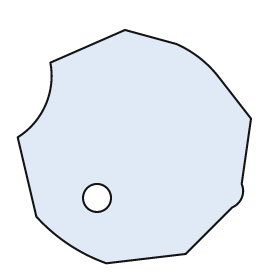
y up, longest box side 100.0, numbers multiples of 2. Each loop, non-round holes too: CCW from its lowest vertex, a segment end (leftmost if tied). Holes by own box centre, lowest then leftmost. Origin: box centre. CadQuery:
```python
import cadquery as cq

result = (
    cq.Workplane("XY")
    .moveTo(-12.0, -50.0)
    .lineTo(22.0, -46.0)
    .lineTo(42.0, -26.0)
    .threePointArc((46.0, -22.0), (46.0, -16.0))
    .lineTo(50.0, 12.0)
    .lineTo(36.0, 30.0)
    .threePointArc((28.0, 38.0), (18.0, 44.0))
    .lineTo(-4.0, 50.0)
    .lineTo(-36.0, 36.0)
    .threePointArc((-38.0, 18.0), (-50.0, 4.0))
    .lineTo(-42.0, -30.0)
    .threePointArc((-28.0, -42.0), (-12.0, -50.0))
    .close()
    .moveTo(-16.0, -22.0)
    .circle(6.0)
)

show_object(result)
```